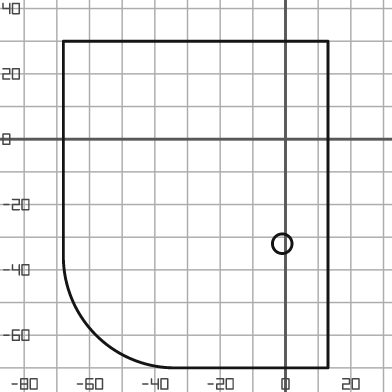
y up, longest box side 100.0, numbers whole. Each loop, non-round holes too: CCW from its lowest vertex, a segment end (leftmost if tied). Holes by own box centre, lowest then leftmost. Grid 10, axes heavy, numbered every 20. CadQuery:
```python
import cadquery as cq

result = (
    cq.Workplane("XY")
    .moveTo(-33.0, -70.0)
    .lineTo(13.0, -70.0)
    .lineTo(13.0, 30.0)
    .lineTo(-68.0, 30.0)
    .lineTo(-68.0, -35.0)
    .threePointArc((-58.0, -60.0), (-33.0, -70.0))
    .close()
    .moveTo(-1.0, -32.0)
    .circle(3.0)
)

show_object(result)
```